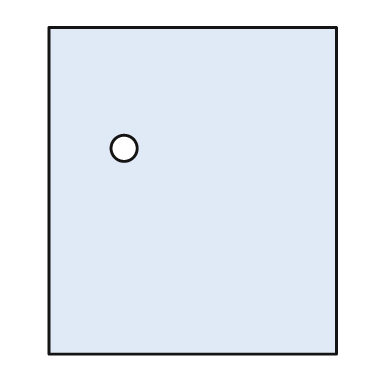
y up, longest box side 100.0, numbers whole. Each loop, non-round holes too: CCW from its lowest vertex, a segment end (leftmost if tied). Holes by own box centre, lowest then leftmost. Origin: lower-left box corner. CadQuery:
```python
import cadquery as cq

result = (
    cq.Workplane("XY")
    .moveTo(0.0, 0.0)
    .lineTo(88.0, 0.0)
    .lineTo(88.0, 100.0)
    .lineTo(0.0, 100.0)
    .close()
    .moveTo(23.0, 63.0)
    .circle(4.0)
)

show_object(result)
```